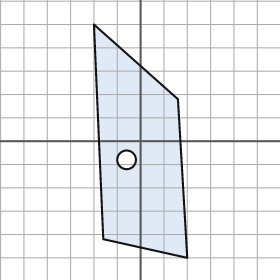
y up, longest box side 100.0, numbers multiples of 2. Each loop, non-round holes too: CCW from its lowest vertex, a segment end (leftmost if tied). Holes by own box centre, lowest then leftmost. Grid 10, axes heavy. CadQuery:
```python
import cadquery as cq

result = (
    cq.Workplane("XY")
    .moveTo(20.0, -50.0)
    .lineTo(16.0, 18.0)
    .lineTo(-20.0, 50.0)
    .lineTo(-16.0, -42.0)
    .close()
    .moveTo(-6.0, -8.0)
    .circle(4.0)
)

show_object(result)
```